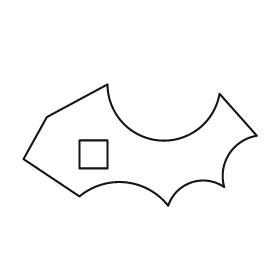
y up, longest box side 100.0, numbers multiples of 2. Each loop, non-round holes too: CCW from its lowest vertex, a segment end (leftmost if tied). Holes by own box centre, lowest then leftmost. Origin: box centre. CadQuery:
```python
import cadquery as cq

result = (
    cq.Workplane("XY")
    .moveTo(12.0, -26.0)
    .threePointArc((22.0, -16.0), (36.0, -18.0))
    .threePointArc((38.0, -4.0), (50.0, 4.0))
    .lineTo(34.0, 22.0)
    .threePointArc((8.0, 2.0), (-14.0, 26.0))
    .lineTo(-40.0, 12.0)
    .lineTo(-50.0, -6.0)
    .lineTo(-26.0, -22.0)
    .threePointArc((-6.0, -16.0), (12.0, -26.0))
    .close()
    .moveTo(-26.0, -10.0)
    .lineTo(-14.0, -10.0)
    .lineTo(-14.0, 2.0)
    .lineTo(-26.0, 2.0)
    .close()
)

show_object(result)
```